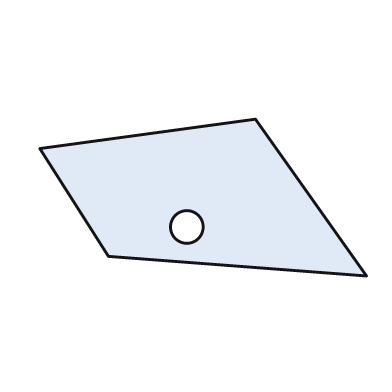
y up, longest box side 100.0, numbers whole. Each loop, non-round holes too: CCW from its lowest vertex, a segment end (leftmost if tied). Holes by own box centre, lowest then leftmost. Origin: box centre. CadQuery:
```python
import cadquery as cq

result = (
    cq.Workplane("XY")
    .moveTo(50.0, -24.0)
    .lineTo(16.0, 24.0)
    .lineTo(-50.0, 15.0)
    .lineTo(-29.0, -18.0)
    .close()
    .moveTo(-5.0, -9.0)
    .circle(5.0)
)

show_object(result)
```